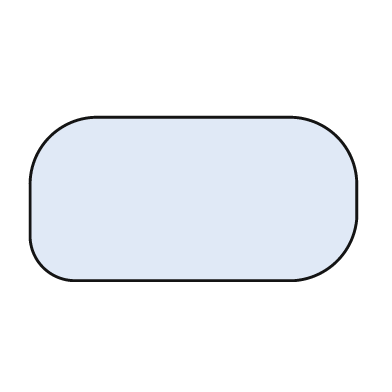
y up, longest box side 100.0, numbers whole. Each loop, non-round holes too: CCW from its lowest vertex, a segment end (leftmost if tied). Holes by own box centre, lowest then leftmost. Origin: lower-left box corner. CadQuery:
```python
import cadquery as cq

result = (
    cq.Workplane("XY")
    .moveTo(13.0, 0.0)
    .lineTo(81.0, 0.0)
    .threePointArc((94.0, 6.0), (100.0, 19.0))
    .lineTo(100.0, 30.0)
    .threePointArc((94.0, 44.0), (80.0, 50.0))
    .lineTo(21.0, 50.0)
    .threePointArc((6.0, 44.0), (0.0, 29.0))
    .lineTo(0.0, 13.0)
    .threePointArc((4.0, 4.0), (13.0, 0.0))
    .close()
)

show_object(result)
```